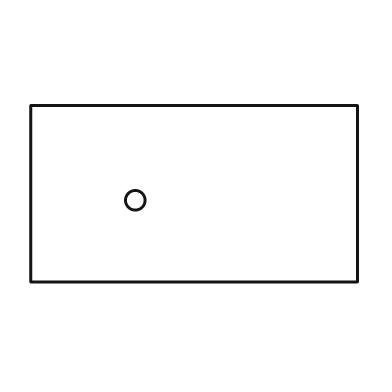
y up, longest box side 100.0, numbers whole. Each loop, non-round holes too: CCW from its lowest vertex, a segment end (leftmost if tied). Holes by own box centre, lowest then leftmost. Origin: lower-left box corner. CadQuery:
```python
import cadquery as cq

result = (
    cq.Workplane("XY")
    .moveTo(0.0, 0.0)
    .lineTo(100.0, 0.0)
    .lineTo(100.0, 54.0)
    .lineTo(0.0, 54.0)
    .close()
    .moveTo(32.0, 25.0)
    .circle(3.0)
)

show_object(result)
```